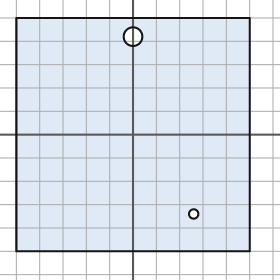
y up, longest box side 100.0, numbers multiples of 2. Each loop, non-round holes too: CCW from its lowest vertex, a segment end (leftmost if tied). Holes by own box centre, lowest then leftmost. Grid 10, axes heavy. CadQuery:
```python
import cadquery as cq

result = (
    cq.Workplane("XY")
    .moveTo(-50.0, -50.0)
    .lineTo(50.0, -50.0)
    .lineTo(50.0, 50.0)
    .lineTo(-50.0, 50.0)
    .close()
    .moveTo(26.0, -34.0)
    .circle(2.0)
    .moveTo(0.0, 42.0)
    .circle(4.0)
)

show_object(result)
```